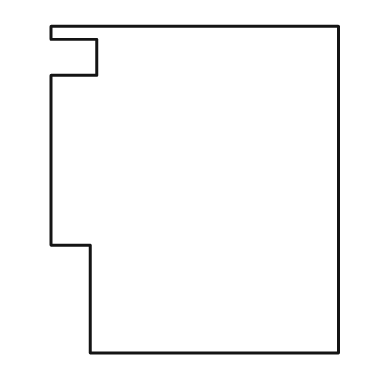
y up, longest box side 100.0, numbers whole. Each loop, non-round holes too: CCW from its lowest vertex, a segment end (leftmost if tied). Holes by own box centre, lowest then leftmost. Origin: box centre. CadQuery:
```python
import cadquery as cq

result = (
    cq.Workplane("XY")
    .moveTo(-32.0, -50.0)
    .lineTo(44.0, -50.0)
    .lineTo(44.0, 50.0)
    .lineTo(-44.0, 50.0)
    .lineTo(-44.0, 46.0)
    .lineTo(-30.0, 46.0)
    .lineTo(-30.0, 35.0)
    .lineTo(-44.0, 35.0)
    .lineTo(-44.0, -17.0)
    .lineTo(-32.0, -17.0)
    .close()
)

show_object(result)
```